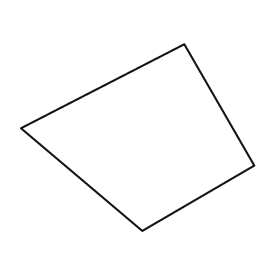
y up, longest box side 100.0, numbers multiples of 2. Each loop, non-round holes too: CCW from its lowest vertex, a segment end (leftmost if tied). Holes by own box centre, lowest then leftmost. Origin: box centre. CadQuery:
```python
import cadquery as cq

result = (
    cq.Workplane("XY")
    .moveTo(2.0, -40.0)
    .lineTo(50.0, -12.0)
    .lineTo(20.0, 40.0)
    .lineTo(-50.0, 4.0)
    .close()
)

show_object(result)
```